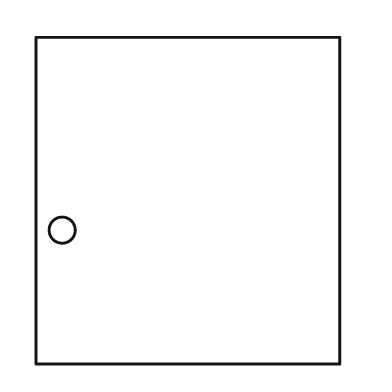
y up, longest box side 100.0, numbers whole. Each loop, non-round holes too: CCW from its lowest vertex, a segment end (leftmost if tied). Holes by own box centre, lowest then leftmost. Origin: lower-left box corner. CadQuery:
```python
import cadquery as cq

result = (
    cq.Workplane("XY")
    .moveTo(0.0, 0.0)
    .lineTo(93.0, 0.0)
    .lineTo(93.0, 100.0)
    .lineTo(0.0, 100.0)
    .close()
    .moveTo(8.0, 41.0)
    .circle(4.0)
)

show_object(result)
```